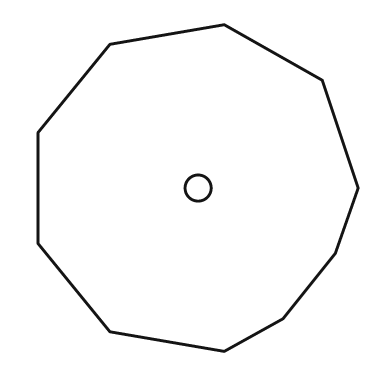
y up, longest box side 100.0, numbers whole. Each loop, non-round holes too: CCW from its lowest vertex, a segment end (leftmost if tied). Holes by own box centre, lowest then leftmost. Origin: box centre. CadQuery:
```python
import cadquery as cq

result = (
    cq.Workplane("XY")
    .moveTo(8.0, -50.0)
    .lineTo(26.0, -40.0)
    .lineTo(42.0, -20.0)
    .lineTo(49.0, 0.0)
    .lineTo(38.0, 33.0)
    .lineTo(8.0, 50.0)
    .lineTo(-27.0, 44.0)
    .lineTo(-49.0, 17.0)
    .lineTo(-49.0, -17.0)
    .lineTo(-27.0, -44.0)
    .close()
    .moveTo(0.0, 0.0)
    .circle(4.0)
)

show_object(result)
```